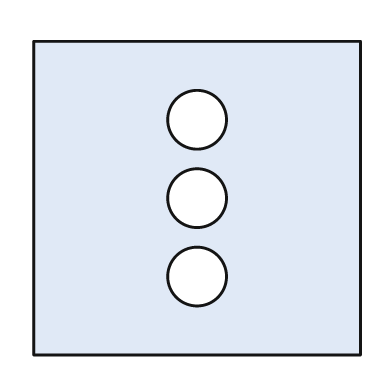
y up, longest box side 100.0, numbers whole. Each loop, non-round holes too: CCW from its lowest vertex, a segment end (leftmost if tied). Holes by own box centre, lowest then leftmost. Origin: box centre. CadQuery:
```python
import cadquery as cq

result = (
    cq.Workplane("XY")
    .moveTo(-50.0, -48.0)
    .lineTo(50.0, -48.0)
    .lineTo(50.0, 48.0)
    .lineTo(-50.0, 48.0)
    .close()
    .moveTo(0.0, -24.0)
    .circle(9.0)
    .moveTo(0.0, 0.0)
    .circle(9.0)
    .moveTo(0.0, 24.0)
    .circle(9.0)
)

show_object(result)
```